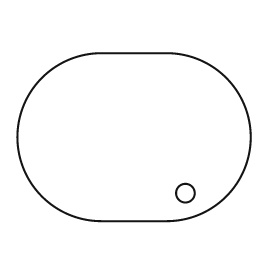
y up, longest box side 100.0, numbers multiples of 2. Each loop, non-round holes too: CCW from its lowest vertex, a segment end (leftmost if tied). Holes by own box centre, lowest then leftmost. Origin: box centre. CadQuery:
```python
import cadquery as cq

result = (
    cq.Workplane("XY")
    .moveTo(-14.0, -36.0)
    .lineTo(14.0, -36.0)
    .threePointArc((50.0, 0.0), (14.0, 36.0))
    .lineTo(-14.0, 36.0)
    .threePointArc((-50.0, 0.0), (-14.0, -36.0))
    .close()
    .moveTo(22.0, -24.0)
    .circle(4.0)
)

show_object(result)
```